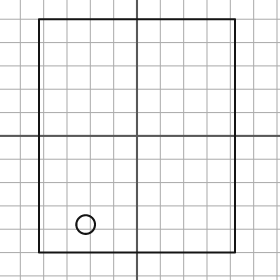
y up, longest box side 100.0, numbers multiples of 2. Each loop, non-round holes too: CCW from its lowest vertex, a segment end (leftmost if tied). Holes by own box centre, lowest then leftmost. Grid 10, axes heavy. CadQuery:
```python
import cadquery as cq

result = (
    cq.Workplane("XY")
    .moveTo(-42.0, -50.0)
    .lineTo(42.0, -50.0)
    .lineTo(42.0, 50.0)
    .lineTo(-42.0, 50.0)
    .close()
    .moveTo(-22.0, -38.0)
    .circle(4.0)
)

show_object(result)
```